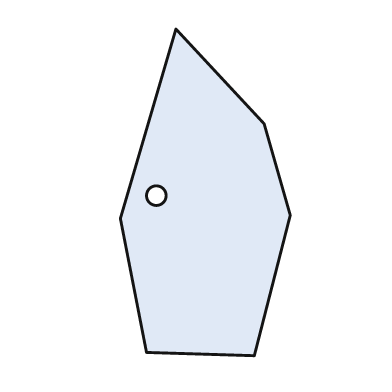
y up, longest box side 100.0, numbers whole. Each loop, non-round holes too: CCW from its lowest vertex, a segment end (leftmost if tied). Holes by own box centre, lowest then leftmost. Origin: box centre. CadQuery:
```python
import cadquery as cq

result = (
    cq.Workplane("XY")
    .moveTo(15.0, -50.0)
    .lineTo(26.0, -7.0)
    .lineTo(18.0, 21.0)
    .lineTo(-9.0, 50.0)
    .lineTo(-26.0, -8.0)
    .lineTo(-18.0, -49.0)
    .close()
    .moveTo(-15.0, -1.0)
    .circle(3.0)
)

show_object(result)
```